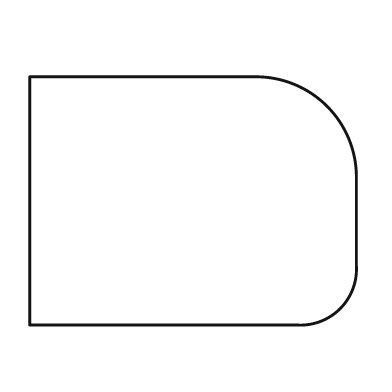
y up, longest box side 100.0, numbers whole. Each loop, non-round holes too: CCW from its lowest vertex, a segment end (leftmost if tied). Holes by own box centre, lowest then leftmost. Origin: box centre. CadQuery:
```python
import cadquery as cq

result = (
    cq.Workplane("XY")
    .moveTo(-50.0, -38.0)
    .lineTo(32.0, -38.0)
    .threePointArc((45.0, -33.0), (50.0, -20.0))
    .lineTo(50.0, 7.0)
    .threePointArc((41.0, 29.0), (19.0, 38.0))
    .lineTo(-50.0, 38.0)
    .close()
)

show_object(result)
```